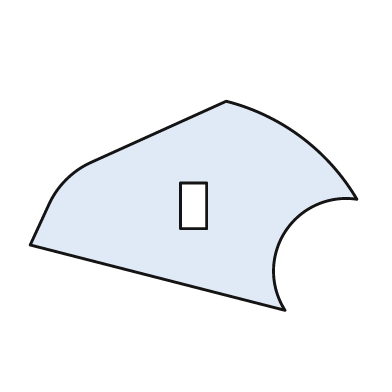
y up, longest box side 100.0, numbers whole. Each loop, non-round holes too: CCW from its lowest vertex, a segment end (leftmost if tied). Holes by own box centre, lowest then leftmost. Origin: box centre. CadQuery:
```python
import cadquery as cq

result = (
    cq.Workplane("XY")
    .moveTo(28.0, -32.0)
    .threePointArc((28.0, -8.0), (50.0, 2.0))
    .threePointArc((33.0, 21.0), (10.0, 32.0))
    .lineTo(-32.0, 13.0)
    .threePointArc((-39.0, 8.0), (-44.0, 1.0))
    .lineTo(-50.0, -12.0)
    .close()
    .moveTo(-4.0, -7.0)
    .lineTo(4.0, -7.0)
    .lineTo(4.0, 7.0)
    .lineTo(-4.0, 7.0)
    .close()
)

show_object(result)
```